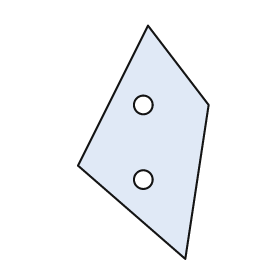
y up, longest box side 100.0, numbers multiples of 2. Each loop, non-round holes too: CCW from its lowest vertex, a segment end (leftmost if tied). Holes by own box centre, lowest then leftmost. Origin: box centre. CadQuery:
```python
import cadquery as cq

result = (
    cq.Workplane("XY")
    .moveTo(18.0, -50.0)
    .lineTo(28.0, 16.0)
    .lineTo(2.0, 50.0)
    .lineTo(-28.0, -10.0)
    .close()
    .moveTo(0.0, -16.0)
    .circle(4.0)
    .moveTo(0.0, 16.0)
    .circle(4.0)
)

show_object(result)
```